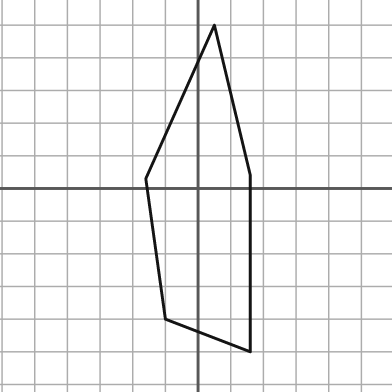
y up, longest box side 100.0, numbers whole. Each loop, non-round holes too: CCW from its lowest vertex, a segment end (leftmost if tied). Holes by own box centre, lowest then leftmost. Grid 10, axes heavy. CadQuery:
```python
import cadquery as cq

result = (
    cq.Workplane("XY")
    .moveTo(16.0, -50.0)
    .lineTo(16.0, 4.0)
    .lineTo(5.0, 50.0)
    .lineTo(-16.0, 3.0)
    .lineTo(-10.0, -40.0)
    .close()
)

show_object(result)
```